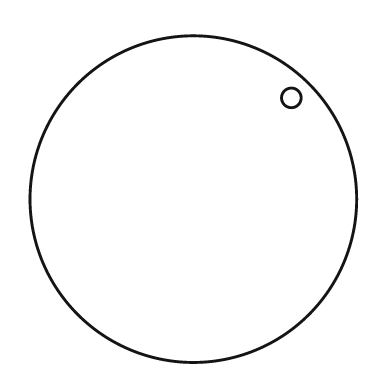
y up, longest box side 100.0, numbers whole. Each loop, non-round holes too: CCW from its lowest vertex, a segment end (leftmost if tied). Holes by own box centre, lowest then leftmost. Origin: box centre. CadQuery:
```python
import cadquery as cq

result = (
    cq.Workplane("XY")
    .moveTo(0.0, 0.0)
    .circle(50.0)
    .moveTo(30.0, 31.0)
    .circle(3.0)
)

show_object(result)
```